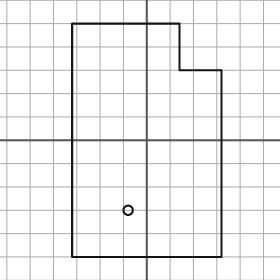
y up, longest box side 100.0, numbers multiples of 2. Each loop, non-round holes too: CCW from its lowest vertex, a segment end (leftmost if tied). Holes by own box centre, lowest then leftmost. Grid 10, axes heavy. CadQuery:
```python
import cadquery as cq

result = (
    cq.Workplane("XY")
    .moveTo(-32.0, -50.0)
    .lineTo(32.0, -50.0)
    .lineTo(32.0, 30.0)
    .lineTo(14.0, 30.0)
    .lineTo(14.0, 50.0)
    .lineTo(-32.0, 50.0)
    .close()
    .moveTo(-8.0, -30.0)
    .circle(2.0)
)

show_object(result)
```